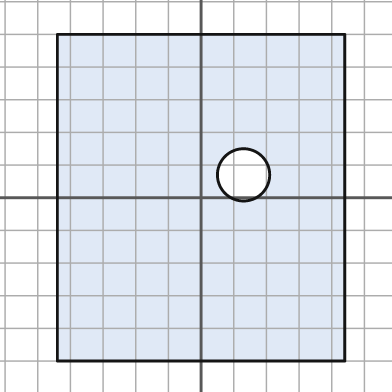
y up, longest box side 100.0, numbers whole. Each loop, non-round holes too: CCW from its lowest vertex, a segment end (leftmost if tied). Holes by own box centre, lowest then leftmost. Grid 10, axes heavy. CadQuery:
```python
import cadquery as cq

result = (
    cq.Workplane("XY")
    .moveTo(-44.0, -50.0)
    .lineTo(44.0, -50.0)
    .lineTo(44.0, 50.0)
    .lineTo(-44.0, 50.0)
    .close()
    .moveTo(13.0, 7.0)
    .circle(8.0)
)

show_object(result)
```